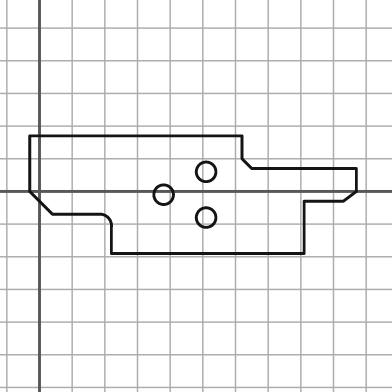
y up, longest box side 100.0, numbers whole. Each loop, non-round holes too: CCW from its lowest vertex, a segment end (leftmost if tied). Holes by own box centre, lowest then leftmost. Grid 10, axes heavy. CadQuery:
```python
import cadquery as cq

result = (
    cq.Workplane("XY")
    .moveTo(22.0, -19.0)
    .lineTo(81.0, -19.0)
    .lineTo(81.0, -3.0)
    .lineTo(93.0, -3.0)
    .lineTo(97.0, 0.0)
    .lineTo(97.0, 7.0)
    .lineTo(65.0, 7.0)
    .lineTo(62.0, 10.0)
    .lineTo(62.0, 17.0)
    .lineTo(-3.0, 17.0)
    .lineTo(-3.0, 0.0)
    .lineTo(4.0, -7.0)
    .lineTo(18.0, -7.0)
    .threePointArc((21.0, -8.0), (22.0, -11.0))
    .close()
    .moveTo(51.0, -8.0)
    .circle(3.0)
    .moveTo(38.0, -1.0)
    .circle(3.0)
    .moveTo(51.0, 6.0)
    .circle(3.0)
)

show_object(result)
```